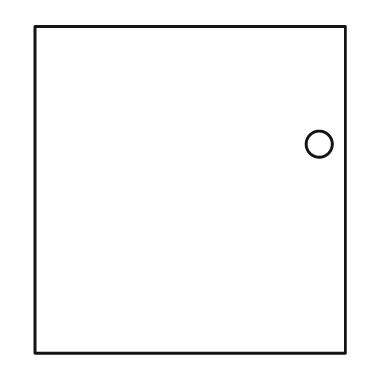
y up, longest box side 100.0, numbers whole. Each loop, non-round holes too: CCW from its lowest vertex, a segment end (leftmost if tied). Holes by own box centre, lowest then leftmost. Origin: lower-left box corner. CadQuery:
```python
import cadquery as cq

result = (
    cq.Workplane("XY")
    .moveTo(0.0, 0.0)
    .lineTo(95.0, 0.0)
    .lineTo(95.0, 100.0)
    .lineTo(0.0, 100.0)
    .close()
    .moveTo(87.0, 64.0)
    .circle(4.0)
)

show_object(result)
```